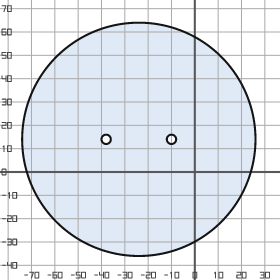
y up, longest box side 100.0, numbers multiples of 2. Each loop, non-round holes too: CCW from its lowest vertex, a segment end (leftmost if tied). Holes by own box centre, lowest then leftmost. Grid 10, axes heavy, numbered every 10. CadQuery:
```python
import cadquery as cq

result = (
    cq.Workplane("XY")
    .moveTo(-24.0, 14.0)
    .circle(50.0)
    .moveTo(-38.0, 14.0)
    .circle(2.0)
    .moveTo(-10.0, 14.0)
    .circle(2.0)
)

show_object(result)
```